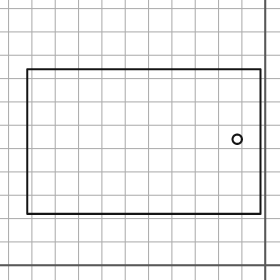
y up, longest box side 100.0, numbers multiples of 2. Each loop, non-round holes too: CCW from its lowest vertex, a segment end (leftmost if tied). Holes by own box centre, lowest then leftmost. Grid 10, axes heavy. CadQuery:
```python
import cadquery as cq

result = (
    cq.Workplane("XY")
    .moveTo(-102.0, 22.0)
    .lineTo(-2.0, 22.0)
    .lineTo(-2.0, 84.0)
    .lineTo(-102.0, 84.0)
    .close()
    .moveTo(-12.0, 54.0)
    .circle(2.0)
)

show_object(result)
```